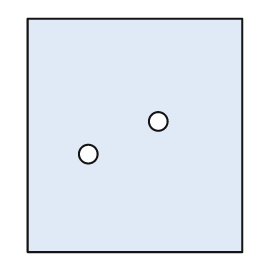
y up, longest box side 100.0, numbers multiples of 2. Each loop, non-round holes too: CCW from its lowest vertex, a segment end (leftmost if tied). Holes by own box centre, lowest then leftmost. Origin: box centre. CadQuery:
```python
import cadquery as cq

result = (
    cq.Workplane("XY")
    .moveTo(-46.0, -50.0)
    .lineTo(46.0, -50.0)
    .lineTo(46.0, 50.0)
    .lineTo(-46.0, 50.0)
    .close()
    .moveTo(-20.0, -8.0)
    .circle(4.0)
    .moveTo(10.0, 6.0)
    .circle(4.0)
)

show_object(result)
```